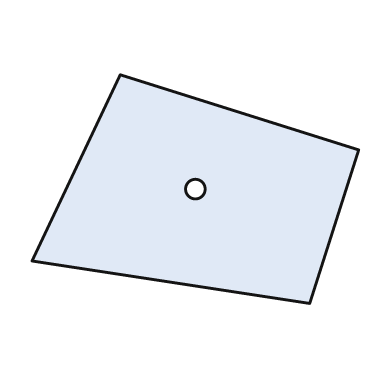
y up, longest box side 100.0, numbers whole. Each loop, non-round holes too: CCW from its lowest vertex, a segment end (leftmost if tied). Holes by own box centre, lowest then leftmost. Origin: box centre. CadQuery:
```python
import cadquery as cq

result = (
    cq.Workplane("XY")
    .moveTo(35.0, -35.0)
    .lineTo(50.0, 12.0)
    .lineTo(-23.0, 35.0)
    .lineTo(-50.0, -22.0)
    .close()
    .moveTo(0.0, 0.0)
    .circle(3.0)
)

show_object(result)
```